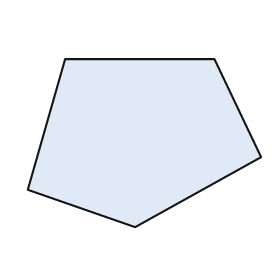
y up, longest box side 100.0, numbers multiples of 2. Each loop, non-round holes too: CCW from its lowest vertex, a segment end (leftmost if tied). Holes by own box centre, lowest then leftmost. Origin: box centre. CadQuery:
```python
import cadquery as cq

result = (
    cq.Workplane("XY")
    .moveTo(-4.0, -36.0)
    .lineTo(50.0, -6.0)
    .lineTo(30.0, 36.0)
    .lineTo(-34.0, 36.0)
    .lineTo(-50.0, -20.0)
    .close()
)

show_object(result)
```